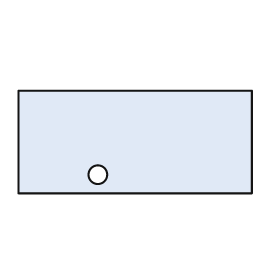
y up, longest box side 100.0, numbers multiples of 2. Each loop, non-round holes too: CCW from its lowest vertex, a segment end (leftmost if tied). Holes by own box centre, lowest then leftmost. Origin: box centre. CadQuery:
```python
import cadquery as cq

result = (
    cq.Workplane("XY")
    .moveTo(-50.0, -22.0)
    .lineTo(50.0, -22.0)
    .lineTo(50.0, 22.0)
    .lineTo(-50.0, 22.0)
    .close()
    .moveTo(-16.0, -14.0)
    .circle(4.0)
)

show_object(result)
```